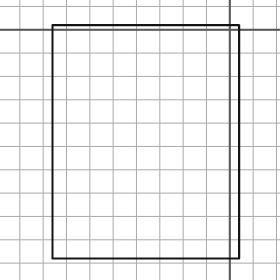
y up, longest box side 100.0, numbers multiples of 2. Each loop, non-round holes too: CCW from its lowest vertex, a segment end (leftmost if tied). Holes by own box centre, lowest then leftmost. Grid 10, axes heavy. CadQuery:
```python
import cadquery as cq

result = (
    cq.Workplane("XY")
    .moveTo(-76.0, -98.0)
    .lineTo(4.0, -98.0)
    .lineTo(4.0, 2.0)
    .lineTo(-76.0, 2.0)
    .close()
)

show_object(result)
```